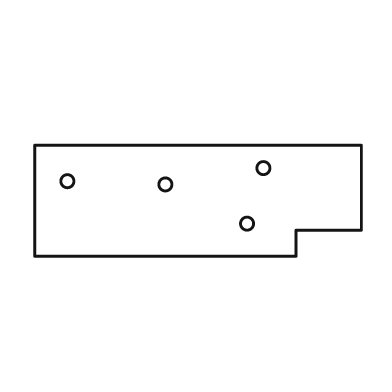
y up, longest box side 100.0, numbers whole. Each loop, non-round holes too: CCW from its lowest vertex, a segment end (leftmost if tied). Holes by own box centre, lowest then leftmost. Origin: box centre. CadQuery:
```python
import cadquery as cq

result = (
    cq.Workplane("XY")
    .moveTo(-50.0, -17.0)
    .lineTo(30.0, -17.0)
    .lineTo(30.0, -9.0)
    .lineTo(50.0, -9.0)
    .lineTo(50.0, 17.0)
    .lineTo(-50.0, 17.0)
    .close()
    .moveTo(15.0, -7.0)
    .circle(2.0)
    .moveTo(-10.0, 5.0)
    .circle(2.0)
    .moveTo(-40.0, 6.0)
    .circle(2.0)
    .moveTo(20.0, 10.0)
    .circle(2.0)
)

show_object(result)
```